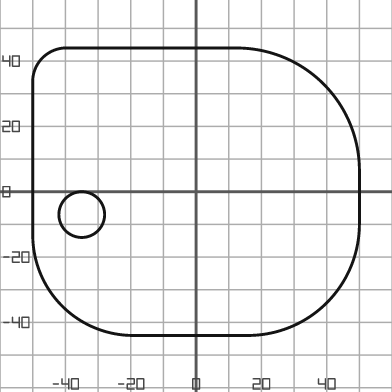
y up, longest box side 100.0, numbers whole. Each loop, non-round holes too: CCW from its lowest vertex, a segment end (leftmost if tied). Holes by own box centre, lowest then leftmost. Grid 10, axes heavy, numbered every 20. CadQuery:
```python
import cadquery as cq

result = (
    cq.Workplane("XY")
    .moveTo(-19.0, -44.0)
    .lineTo(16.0, -44.0)
    .threePointArc((40.0, -34.0), (50.0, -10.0))
    .lineTo(50.0, 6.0)
    .threePointArc((39.0, 33.0), (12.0, 44.0))
    .lineTo(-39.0, 44.0)
    .threePointArc((-47.0, 41.0), (-50.0, 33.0))
    .lineTo(-50.0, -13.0)
    .threePointArc((-41.0, -35.0), (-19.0, -44.0))
    .close()
    .moveTo(-35.0, -7.0)
    .circle(7.0)
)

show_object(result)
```